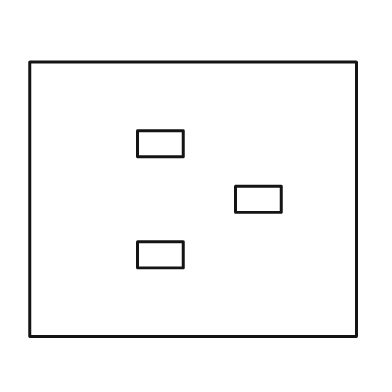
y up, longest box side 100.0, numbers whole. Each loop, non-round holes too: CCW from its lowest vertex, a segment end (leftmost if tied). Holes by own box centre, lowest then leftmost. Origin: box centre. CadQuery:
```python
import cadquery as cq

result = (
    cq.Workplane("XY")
    .moveTo(-50.0, -42.0)
    .lineTo(50.0, -42.0)
    .lineTo(50.0, 42.0)
    .lineTo(-50.0, 42.0)
    .close()
    .moveTo(-17.0, -21.0)
    .lineTo(-3.0, -21.0)
    .lineTo(-3.0, -13.0)
    .lineTo(-17.0, -13.0)
    .close()
    .moveTo(13.0, -4.0)
    .lineTo(27.0, -4.0)
    .lineTo(27.0, 4.0)
    .lineTo(13.0, 4.0)
    .close()
    .moveTo(-17.0, 13.0)
    .lineTo(-3.0, 13.0)
    .lineTo(-3.0, 21.0)
    .lineTo(-17.0, 21.0)
    .close()
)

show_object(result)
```